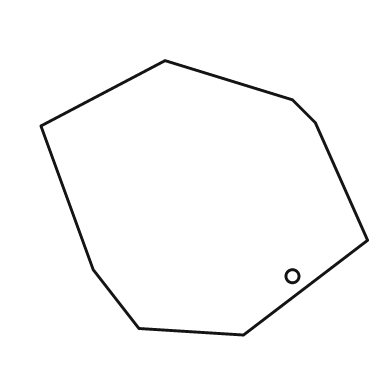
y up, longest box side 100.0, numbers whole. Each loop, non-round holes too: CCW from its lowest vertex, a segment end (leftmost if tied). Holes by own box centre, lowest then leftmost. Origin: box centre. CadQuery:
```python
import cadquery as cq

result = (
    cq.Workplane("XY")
    .moveTo(12.0, -42.0)
    .lineTo(50.0, -13.0)
    .lineTo(34.0, 23.0)
    .lineTo(27.0, 30.0)
    .lineTo(-12.0, 42.0)
    .lineTo(-50.0, 22.0)
    .lineTo(-34.0, -22.0)
    .lineTo(-20.0, -40.0)
    .close()
    .moveTo(27.0, -24.0)
    .circle(2.0)
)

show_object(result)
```